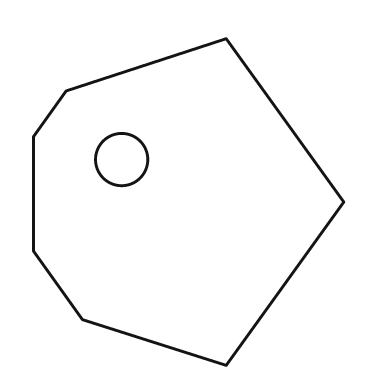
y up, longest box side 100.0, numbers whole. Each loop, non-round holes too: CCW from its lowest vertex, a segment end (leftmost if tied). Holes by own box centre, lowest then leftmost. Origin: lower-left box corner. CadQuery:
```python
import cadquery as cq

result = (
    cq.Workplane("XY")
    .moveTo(59.0, 0.0)
    .lineTo(95.0, 50.0)
    .lineTo(59.0, 100.0)
    .lineTo(10.0, 84.0)
    .lineTo(0.0, 70.0)
    .lineTo(0.0, 35.0)
    .lineTo(15.0, 14.0)
    .close()
    .moveTo(27.0, 63.0)
    .circle(8.0)
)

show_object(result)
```